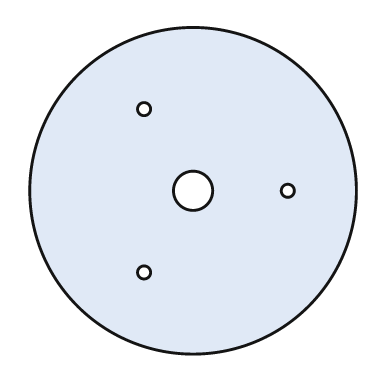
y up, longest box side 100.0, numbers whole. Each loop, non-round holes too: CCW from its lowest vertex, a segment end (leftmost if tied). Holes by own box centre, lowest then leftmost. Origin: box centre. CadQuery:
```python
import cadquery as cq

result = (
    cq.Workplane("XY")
    .moveTo(0.0, 0.0)
    .circle(50.0)
    .moveTo(-15.0, -25.0)
    .circle(2.0)
    .moveTo(0.0, 0.0)
    .circle(6.0)
    .moveTo(29.0, 0.0)
    .circle(2.0)
    .moveTo(-15.0, 25.0)
    .circle(2.0)
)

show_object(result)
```